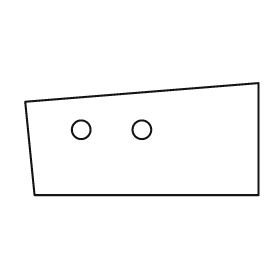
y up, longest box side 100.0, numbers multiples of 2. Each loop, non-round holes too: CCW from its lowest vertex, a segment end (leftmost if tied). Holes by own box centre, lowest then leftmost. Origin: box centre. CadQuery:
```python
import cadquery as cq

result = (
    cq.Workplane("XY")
    .moveTo(-46.0, -24.0)
    .lineTo(50.0, -24.0)
    .lineTo(50.0, 24.0)
    .lineTo(-50.0, 16.0)
    .close()
    .moveTo(-26.0, 4.0)
    .circle(4.0)
    .moveTo(0.0, 4.0)
    .circle(4.0)
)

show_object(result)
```